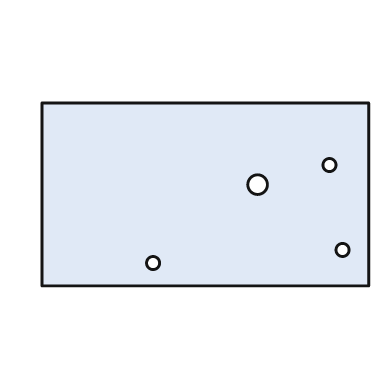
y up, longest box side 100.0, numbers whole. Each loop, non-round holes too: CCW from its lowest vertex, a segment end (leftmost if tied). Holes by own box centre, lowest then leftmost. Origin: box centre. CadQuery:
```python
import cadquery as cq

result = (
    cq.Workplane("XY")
    .moveTo(-50.0, -28.0)
    .lineTo(50.0, -28.0)
    .lineTo(50.0, 28.0)
    .lineTo(-50.0, 28.0)
    .close()
    .moveTo(-16.0, -21.0)
    .circle(2.0)
    .moveTo(42.0, -17.0)
    .circle(2.0)
    .moveTo(16.0, 3.0)
    .circle(3.0)
    .moveTo(38.0, 9.0)
    .circle(2.0)
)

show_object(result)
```